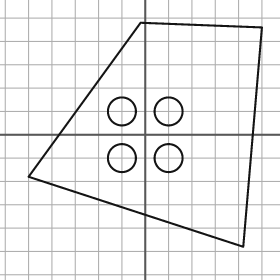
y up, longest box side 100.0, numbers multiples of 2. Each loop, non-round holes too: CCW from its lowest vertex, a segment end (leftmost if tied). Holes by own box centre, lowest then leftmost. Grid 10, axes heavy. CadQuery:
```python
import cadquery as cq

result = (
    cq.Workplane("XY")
    .moveTo(42.0, -48.0)
    .lineTo(50.0, 46.0)
    .lineTo(-2.0, 48.0)
    .lineTo(-50.0, -18.0)
    .close()
    .moveTo(-10.0, -10.0)
    .circle(6.0)
    .moveTo(10.0, -10.0)
    .circle(6.0)
    .moveTo(-10.0, 10.0)
    .circle(6.0)
    .moveTo(10.0, 10.0)
    .circle(6.0)
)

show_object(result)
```